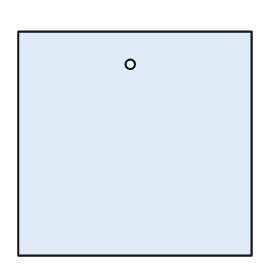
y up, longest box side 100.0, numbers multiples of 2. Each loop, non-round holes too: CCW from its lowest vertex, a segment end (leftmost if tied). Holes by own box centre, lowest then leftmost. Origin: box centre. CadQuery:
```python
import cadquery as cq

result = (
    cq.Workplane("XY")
    .moveTo(-50.0, -48.0)
    .lineTo(50.0, -48.0)
    .lineTo(50.0, 48.0)
    .lineTo(-50.0, 48.0)
    .close()
    .moveTo(-2.0, 34.0)
    .circle(2.0)
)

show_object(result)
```